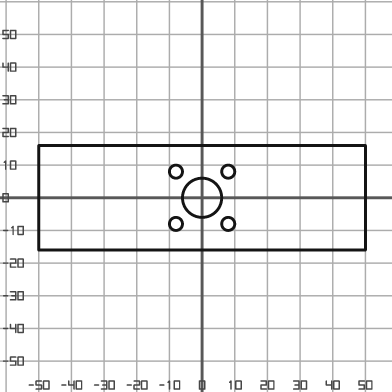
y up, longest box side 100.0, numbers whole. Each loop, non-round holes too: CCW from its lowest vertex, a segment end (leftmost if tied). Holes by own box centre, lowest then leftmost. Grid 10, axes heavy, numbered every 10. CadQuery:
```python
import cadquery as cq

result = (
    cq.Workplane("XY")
    .moveTo(-50.0, -16.0)
    .lineTo(50.0, -16.0)
    .lineTo(50.0, 16.0)
    .lineTo(-50.0, 16.0)
    .close()
    .moveTo(-8.0, -8.0)
    .circle(2.0)
    .moveTo(8.0, -8.0)
    .circle(2.0)
    .moveTo(0.0, 0.0)
    .circle(6.0)
    .moveTo(-8.0, 8.0)
    .circle(2.0)
    .moveTo(8.0, 8.0)
    .circle(2.0)
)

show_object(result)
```